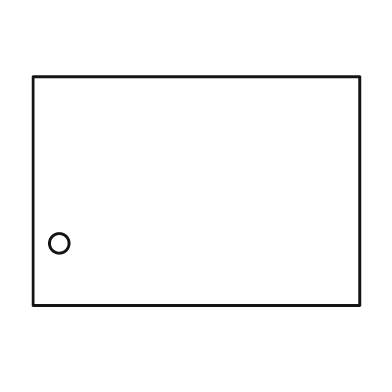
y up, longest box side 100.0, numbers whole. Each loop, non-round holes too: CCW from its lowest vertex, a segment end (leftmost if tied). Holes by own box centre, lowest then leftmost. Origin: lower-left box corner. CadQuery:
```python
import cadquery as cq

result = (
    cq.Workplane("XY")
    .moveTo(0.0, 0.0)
    .lineTo(100.0, 0.0)
    .lineTo(100.0, 70.0)
    .lineTo(0.0, 70.0)
    .close()
    .moveTo(8.0, 19.0)
    .circle(3.0)
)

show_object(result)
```